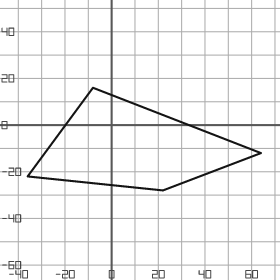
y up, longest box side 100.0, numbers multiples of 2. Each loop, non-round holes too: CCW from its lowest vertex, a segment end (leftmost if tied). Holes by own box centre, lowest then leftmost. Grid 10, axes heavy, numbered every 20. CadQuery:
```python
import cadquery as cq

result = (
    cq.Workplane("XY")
    .moveTo(22.0, -28.0)
    .lineTo(64.0, -12.0)
    .lineTo(-8.0, 16.0)
    .lineTo(-36.0, -22.0)
    .close()
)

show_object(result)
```